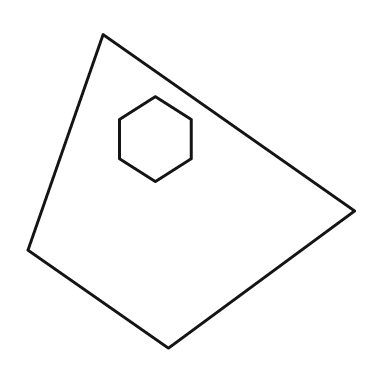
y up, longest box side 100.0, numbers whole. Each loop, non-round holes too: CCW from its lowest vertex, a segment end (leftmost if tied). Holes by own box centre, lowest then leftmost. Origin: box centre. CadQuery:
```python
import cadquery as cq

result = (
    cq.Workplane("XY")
    .moveTo(-7.0, -48.0)
    .lineTo(50.0, -6.0)
    .lineTo(-27.0, 48.0)
    .lineTo(-50.0, -18.0)
    .close()
    .moveTo(-11.0, 3.0)
    .lineTo(0.0, 10.0)
    .lineTo(0.0, 22.0)
    .lineTo(-11.0, 29.0)
    .lineTo(-22.0, 22.0)
    .lineTo(-22.0, 10.0)
    .close()
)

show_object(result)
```